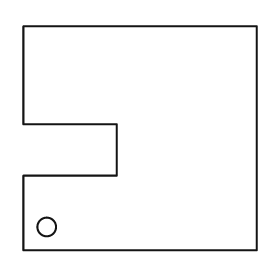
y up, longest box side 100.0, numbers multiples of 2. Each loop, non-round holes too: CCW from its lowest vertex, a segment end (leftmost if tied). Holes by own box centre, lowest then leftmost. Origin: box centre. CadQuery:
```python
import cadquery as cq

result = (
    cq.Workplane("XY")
    .moveTo(-50.0, -48.0)
    .lineTo(50.0, -48.0)
    .lineTo(50.0, 48.0)
    .lineTo(-50.0, 48.0)
    .lineTo(-50.0, 6.0)
    .lineTo(-10.0, 6.0)
    .lineTo(-10.0, -16.0)
    .lineTo(-50.0, -16.0)
    .close()
    .moveTo(-40.0, -38.0)
    .circle(4.0)
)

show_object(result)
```